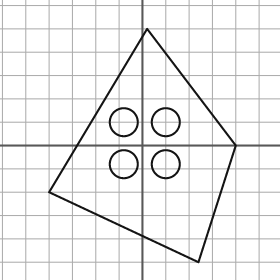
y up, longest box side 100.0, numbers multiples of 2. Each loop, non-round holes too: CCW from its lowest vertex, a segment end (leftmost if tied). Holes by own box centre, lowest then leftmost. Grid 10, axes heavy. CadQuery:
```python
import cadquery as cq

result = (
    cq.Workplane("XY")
    .moveTo(24.0, -50.0)
    .lineTo(40.0, 0.0)
    .lineTo(2.0, 50.0)
    .lineTo(-40.0, -20.0)
    .close()
    .moveTo(-8.0, -8.0)
    .circle(6.0)
    .moveTo(10.0, -8.0)
    .circle(6.0)
    .moveTo(-8.0, 10.0)
    .circle(6.0)
    .moveTo(10.0, 10.0)
    .circle(6.0)
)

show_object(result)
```